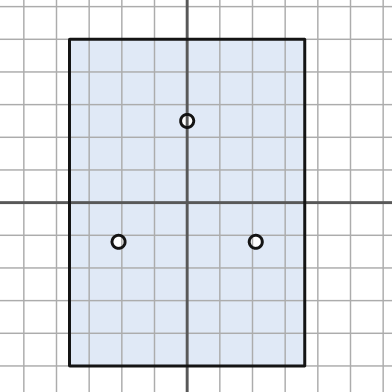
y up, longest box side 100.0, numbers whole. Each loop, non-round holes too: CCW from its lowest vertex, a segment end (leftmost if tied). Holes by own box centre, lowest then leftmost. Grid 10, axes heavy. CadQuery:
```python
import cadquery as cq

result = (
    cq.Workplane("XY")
    .moveTo(-36.0, -50.0)
    .lineTo(36.0, -50.0)
    .lineTo(36.0, 50.0)
    .lineTo(-36.0, 50.0)
    .close()
    .moveTo(-21.0, -12.0)
    .circle(2.0)
    .moveTo(21.0, -12.0)
    .circle(2.0)
    .moveTo(0.0, 25.0)
    .circle(2.0)
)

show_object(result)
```